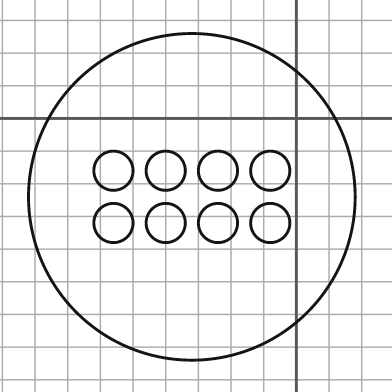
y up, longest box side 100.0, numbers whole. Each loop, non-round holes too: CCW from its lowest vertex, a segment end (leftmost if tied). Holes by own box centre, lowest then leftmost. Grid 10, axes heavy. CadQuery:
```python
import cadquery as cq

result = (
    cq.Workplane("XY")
    .moveTo(-32.0, -24.0)
    .circle(50.0)
    .moveTo(-56.0, -32.0)
    .circle(6.0)
    .moveTo(-40.0, -32.0)
    .circle(6.0)
    .moveTo(-24.0, -32.0)
    .circle(6.0)
    .moveTo(-8.0, -32.0)
    .circle(6.0)
    .moveTo(-56.0, -16.0)
    .circle(6.0)
    .moveTo(-40.0, -16.0)
    .circle(6.0)
    .moveTo(-24.0, -16.0)
    .circle(6.0)
    .moveTo(-8.0, -16.0)
    .circle(6.0)
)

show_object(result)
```